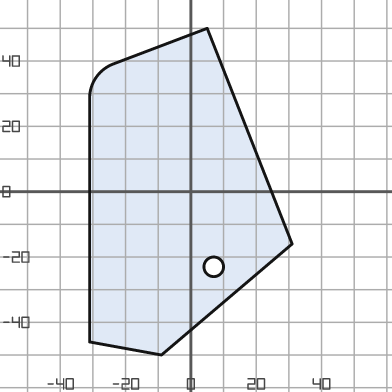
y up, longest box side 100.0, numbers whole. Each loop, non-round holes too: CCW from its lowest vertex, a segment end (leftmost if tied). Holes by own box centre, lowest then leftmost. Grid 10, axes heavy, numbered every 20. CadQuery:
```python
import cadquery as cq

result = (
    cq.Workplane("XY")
    .moveTo(-9.0, -50.0)
    .lineTo(31.0, -16.0)
    .lineTo(5.0, 50.0)
    .lineTo(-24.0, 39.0)
    .threePointArc((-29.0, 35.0), (-31.0, 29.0))
    .lineTo(-31.0, -46.0)
    .close()
    .moveTo(7.0, -23.0)
    .circle(3.0)
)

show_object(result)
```